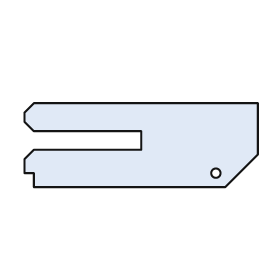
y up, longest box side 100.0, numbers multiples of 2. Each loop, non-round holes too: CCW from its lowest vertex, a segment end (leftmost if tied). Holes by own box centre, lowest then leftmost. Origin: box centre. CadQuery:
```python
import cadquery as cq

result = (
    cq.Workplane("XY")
    .moveTo(-46.0, -18.0)
    .lineTo(36.0, -18.0)
    .lineTo(50.0, -4.0)
    .lineTo(50.0, 18.0)
    .lineTo(-46.0, 18.0)
    .lineTo(-50.0, 14.0)
    .lineTo(-50.0, 10.0)
    .lineTo(-46.0, 6.0)
    .lineTo(0.0, 6.0)
    .lineTo(0.0, -2.0)
    .lineTo(-46.0, -2.0)
    .lineTo(-50.0, -6.0)
    .lineTo(-50.0, -12.0)
    .lineTo(-46.0, -12.0)
    .close()
    .moveTo(32.0, -12.0)
    .circle(2.0)
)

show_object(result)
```